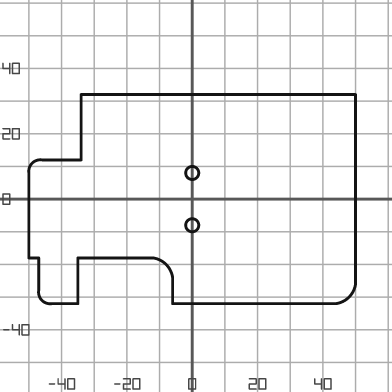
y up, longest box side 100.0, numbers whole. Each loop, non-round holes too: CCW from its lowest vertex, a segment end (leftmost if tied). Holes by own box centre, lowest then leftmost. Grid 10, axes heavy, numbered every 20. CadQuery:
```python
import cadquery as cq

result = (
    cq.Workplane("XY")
    .moveTo(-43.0, -32.0)
    .lineTo(-35.0, -32.0)
    .lineTo(-35.0, -18.0)
    .lineTo(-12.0, -18.0)
    .threePointArc((-8.0, -20.0), (-6.0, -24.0))
    .lineTo(-6.0, -32.0)
    .lineTo(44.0, -32.0)
    .threePointArc((48.0, -30.0), (50.0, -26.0))
    .lineTo(50.0, 32.0)
    .lineTo(-34.0, 32.0)
    .lineTo(-34.0, 12.0)
    .lineTo(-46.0, 12.0)
    .threePointArc((-49.0, 11.0), (-50.0, 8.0))
    .lineTo(-50.0, -18.0)
    .lineTo(-47.0, -18.0)
    .lineTo(-47.0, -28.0)
    .threePointArc((-46.0, -31.0), (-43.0, -32.0))
    .close()
    .moveTo(0.0, -8.0)
    .circle(2.0)
    .moveTo(0.0, 8.0)
    .circle(2.0)
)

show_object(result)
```